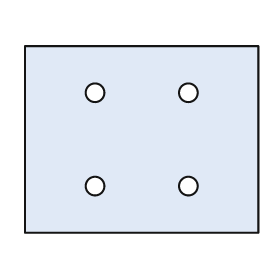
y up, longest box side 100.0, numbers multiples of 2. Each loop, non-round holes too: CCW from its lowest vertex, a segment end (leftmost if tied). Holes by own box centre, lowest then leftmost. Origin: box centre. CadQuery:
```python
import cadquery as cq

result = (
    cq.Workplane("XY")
    .moveTo(-50.0, -40.0)
    .lineTo(50.0, -40.0)
    .lineTo(50.0, 40.0)
    .lineTo(-50.0, 40.0)
    .close()
    .moveTo(-20.0, -20.0)
    .circle(4.0)
    .moveTo(20.0, -20.0)
    .circle(4.0)
    .moveTo(-20.0, 20.0)
    .circle(4.0)
    .moveTo(20.0, 20.0)
    .circle(4.0)
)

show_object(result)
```